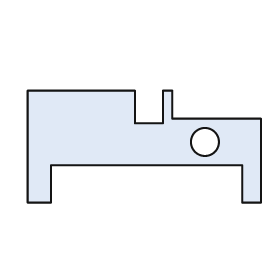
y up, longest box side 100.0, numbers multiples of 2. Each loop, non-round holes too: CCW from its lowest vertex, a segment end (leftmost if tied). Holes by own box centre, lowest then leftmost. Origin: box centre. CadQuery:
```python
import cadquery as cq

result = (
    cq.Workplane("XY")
    .moveTo(-50.0, -24.0)
    .lineTo(-40.0, -24.0)
    .lineTo(-40.0, -8.0)
    .lineTo(42.0, -8.0)
    .lineTo(42.0, -24.0)
    .lineTo(50.0, -24.0)
    .lineTo(50.0, 12.0)
    .lineTo(12.0, 12.0)
    .lineTo(12.0, 24.0)
    .lineTo(8.0, 24.0)
    .lineTo(8.0, 10.0)
    .lineTo(-4.0, 10.0)
    .lineTo(-4.0, 24.0)
    .lineTo(-50.0, 24.0)
    .close()
    .moveTo(26.0, 2.0)
    .circle(6.0)
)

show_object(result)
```